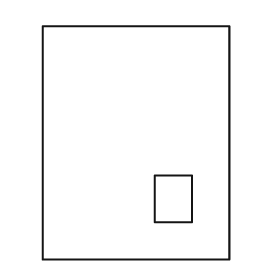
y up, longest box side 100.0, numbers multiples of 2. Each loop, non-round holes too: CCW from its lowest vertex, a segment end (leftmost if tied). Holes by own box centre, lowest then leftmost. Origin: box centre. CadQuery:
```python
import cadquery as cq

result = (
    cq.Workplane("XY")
    .moveTo(-40.0, -50.0)
    .lineTo(40.0, -50.0)
    .lineTo(40.0, 50.0)
    .lineTo(-40.0, 50.0)
    .close()
    .moveTo(8.0, -34.0)
    .lineTo(24.0, -34.0)
    .lineTo(24.0, -14.0)
    .lineTo(8.0, -14.0)
    .close()
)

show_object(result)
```